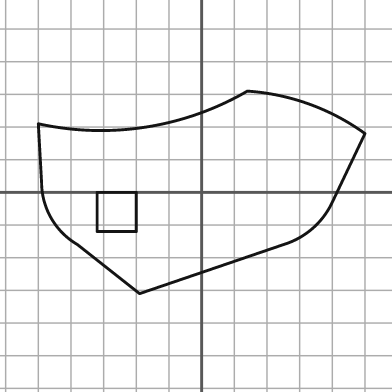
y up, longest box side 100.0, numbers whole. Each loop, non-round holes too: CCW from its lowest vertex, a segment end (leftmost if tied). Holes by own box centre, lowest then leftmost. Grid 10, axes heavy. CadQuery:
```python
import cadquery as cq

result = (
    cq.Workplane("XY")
    .moveTo(-19.0, -31.0)
    .lineTo(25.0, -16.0)
    .threePointArc((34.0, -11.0), (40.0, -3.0))
    .lineTo(50.0, 18.0)
    .threePointArc((33.0, 27.0), (14.0, 31.0))
    .threePointArc((-17.0, 20.0), (-50.0, 21.0))
    .lineTo(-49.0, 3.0)
    .threePointArc((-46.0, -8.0), (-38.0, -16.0))
    .close()
    .moveTo(-32.0, -12.0)
    .lineTo(-20.0, -12.0)
    .lineTo(-20.0, 0.0)
    .lineTo(-32.0, 0.0)
    .close()
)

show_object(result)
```